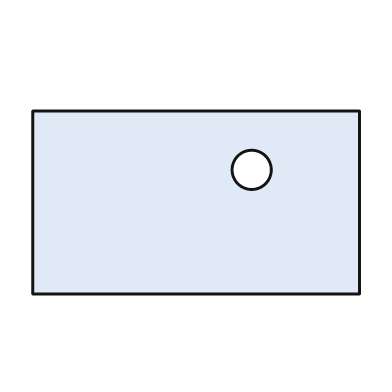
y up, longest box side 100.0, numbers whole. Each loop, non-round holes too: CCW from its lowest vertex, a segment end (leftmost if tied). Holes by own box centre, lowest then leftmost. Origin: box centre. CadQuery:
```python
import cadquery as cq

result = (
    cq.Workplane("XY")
    .moveTo(-50.0, -28.0)
    .lineTo(50.0, -28.0)
    .lineTo(50.0, 28.0)
    .lineTo(-50.0, 28.0)
    .close()
    .moveTo(17.0, 10.0)
    .circle(6.0)
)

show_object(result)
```